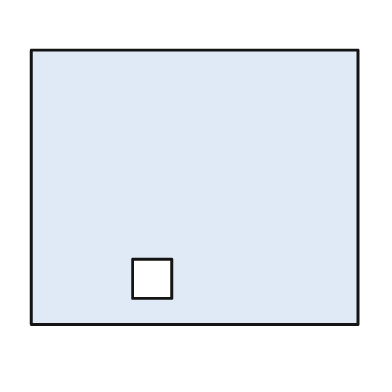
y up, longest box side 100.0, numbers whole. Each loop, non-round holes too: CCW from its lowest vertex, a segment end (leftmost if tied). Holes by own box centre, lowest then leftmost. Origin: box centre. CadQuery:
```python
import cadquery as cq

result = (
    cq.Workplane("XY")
    .moveTo(-50.0, -42.0)
    .lineTo(50.0, -42.0)
    .lineTo(50.0, 42.0)
    .lineTo(-50.0, 42.0)
    .close()
    .moveTo(-19.0, -34.0)
    .lineTo(-7.0, -34.0)
    .lineTo(-7.0, -22.0)
    .lineTo(-19.0, -22.0)
    .close()
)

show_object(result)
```